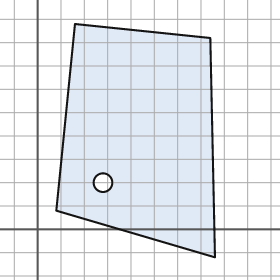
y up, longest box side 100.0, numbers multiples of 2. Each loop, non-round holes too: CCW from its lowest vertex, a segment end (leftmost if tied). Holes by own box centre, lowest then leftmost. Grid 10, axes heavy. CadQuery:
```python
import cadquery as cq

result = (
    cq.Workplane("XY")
    .moveTo(76.0, -12.0)
    .lineTo(74.0, 82.0)
    .lineTo(16.0, 88.0)
    .lineTo(8.0, 8.0)
    .close()
    .moveTo(28.0, 20.0)
    .circle(4.0)
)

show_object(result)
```